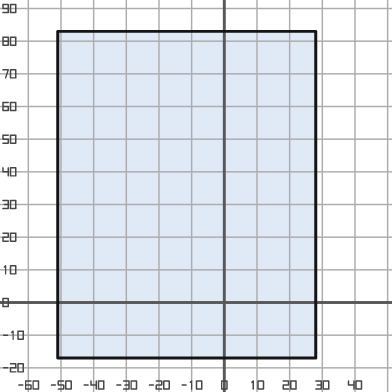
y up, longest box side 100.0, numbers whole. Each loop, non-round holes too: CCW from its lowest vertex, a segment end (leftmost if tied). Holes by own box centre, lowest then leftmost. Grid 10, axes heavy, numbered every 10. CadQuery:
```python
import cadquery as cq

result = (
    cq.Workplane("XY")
    .moveTo(-51.0, -17.0)
    .lineTo(28.0, -17.0)
    .lineTo(28.0, 83.0)
    .lineTo(-51.0, 83.0)
    .close()
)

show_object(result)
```